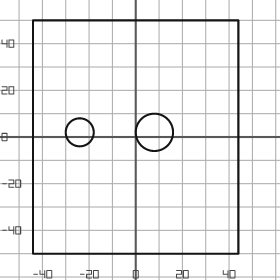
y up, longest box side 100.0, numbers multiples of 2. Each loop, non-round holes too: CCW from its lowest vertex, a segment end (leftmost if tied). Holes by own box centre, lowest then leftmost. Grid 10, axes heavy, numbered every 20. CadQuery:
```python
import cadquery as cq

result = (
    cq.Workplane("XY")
    .moveTo(-44.0, -50.0)
    .lineTo(44.0, -50.0)
    .lineTo(44.0, 50.0)
    .lineTo(-44.0, 50.0)
    .close()
    .moveTo(-24.0, 2.0)
    .circle(6.0)
    .moveTo(8.0, 2.0)
    .circle(8.0)
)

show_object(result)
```